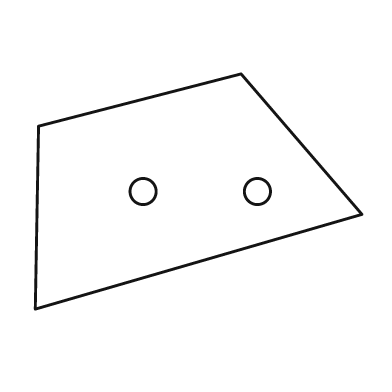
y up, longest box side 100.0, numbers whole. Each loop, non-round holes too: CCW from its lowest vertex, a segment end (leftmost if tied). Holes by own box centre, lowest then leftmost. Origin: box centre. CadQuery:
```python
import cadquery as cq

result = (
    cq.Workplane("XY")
    .moveTo(-50.0, -36.0)
    .lineTo(50.0, -7.0)
    .lineTo(13.0, 36.0)
    .lineTo(-49.0, 20.0)
    .close()
    .moveTo(-17.0, 0.0)
    .circle(4.0)
    .moveTo(18.0, 0.0)
    .circle(4.0)
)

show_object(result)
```